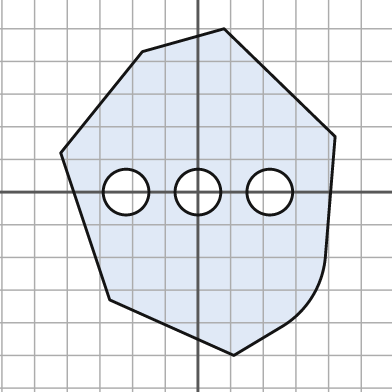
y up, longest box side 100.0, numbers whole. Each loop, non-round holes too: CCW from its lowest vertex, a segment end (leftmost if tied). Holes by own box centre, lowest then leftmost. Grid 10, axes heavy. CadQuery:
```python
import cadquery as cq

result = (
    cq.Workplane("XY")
    .moveTo(11.0, -50.0)
    .lineTo(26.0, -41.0)
    .threePointArc((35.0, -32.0), (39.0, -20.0))
    .lineTo(42.0, 17.0)
    .lineTo(8.0, 50.0)
    .lineTo(-17.0, 43.0)
    .lineTo(-42.0, 12.0)
    .lineTo(-27.0, -33.0)
    .close()
    .moveTo(-22.0, 0.0)
    .circle(7.0)
    .moveTo(0.0, 0.0)
    .circle(7.0)
    .moveTo(22.0, 0.0)
    .circle(7.0)
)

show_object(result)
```